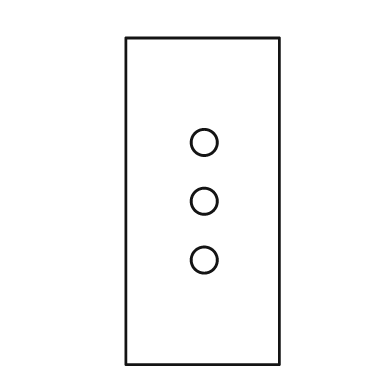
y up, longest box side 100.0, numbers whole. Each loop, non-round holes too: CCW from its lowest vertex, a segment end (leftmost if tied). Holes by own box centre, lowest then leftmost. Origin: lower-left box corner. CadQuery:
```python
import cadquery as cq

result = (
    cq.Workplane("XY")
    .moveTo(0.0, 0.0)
    .lineTo(47.0, 0.0)
    .lineTo(47.0, 100.0)
    .lineTo(0.0, 100.0)
    .close()
    .moveTo(24.0, 32.0)
    .circle(4.0)
    .moveTo(24.0, 50.0)
    .circle(4.0)
    .moveTo(24.0, 68.0)
    .circle(4.0)
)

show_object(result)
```